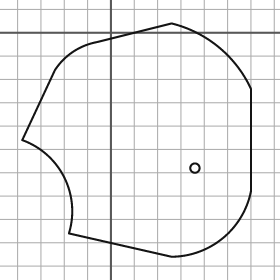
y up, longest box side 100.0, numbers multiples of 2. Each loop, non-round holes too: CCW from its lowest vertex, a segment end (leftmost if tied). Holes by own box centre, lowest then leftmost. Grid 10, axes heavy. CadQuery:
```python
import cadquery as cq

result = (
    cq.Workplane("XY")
    .moveTo(26.0, -96.0)
    .threePointArc((48.0, -88.0), (60.0, -68.0))
    .lineTo(60.0, -24.0)
    .threePointArc((46.0, -6.0), (26.0, 4.0))
    .lineTo(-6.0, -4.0)
    .threePointArc((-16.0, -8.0), (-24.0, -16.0))
    .lineTo(-38.0, -46.0)
    .threePointArc((-20.0, -62.0), (-18.0, -86.0))
    .close()
    .moveTo(36.0, -58.0)
    .circle(2.0)
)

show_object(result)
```